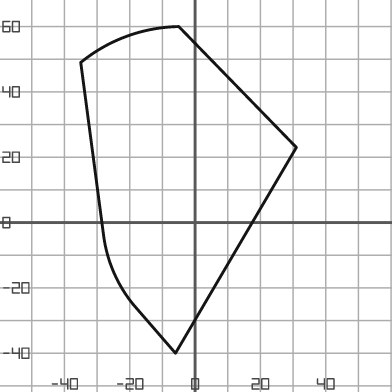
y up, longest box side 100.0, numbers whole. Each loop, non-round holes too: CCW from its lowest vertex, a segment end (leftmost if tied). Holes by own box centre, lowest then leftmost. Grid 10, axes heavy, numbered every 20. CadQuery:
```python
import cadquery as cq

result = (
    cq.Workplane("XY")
    .moveTo(-6.0, -40.0)
    .lineTo(31.0, 23.0)
    .lineTo(-5.0, 60.0)
    .threePointArc((-21.0, 57.0), (-35.0, 49.0))
    .lineTo(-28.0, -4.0)
    .threePointArc((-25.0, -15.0), (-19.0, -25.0))
    .close()
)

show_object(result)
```